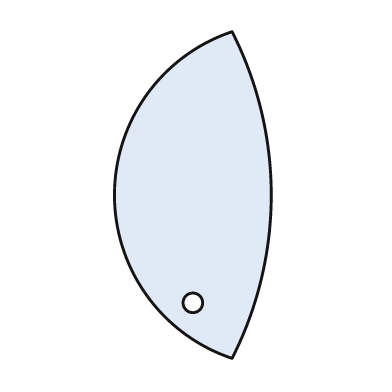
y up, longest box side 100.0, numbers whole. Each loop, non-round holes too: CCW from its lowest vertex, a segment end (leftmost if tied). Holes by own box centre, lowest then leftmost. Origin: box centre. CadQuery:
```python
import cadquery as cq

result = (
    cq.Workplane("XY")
    .moveTo(12.0, -50.0)
    .threePointArc((24.0, 0.0), (12.0, 50.0))
    .threePointArc((-24.0, 0.0), (12.0, -50.0))
    .close()
    .moveTo(0.0, -33.0)
    .circle(3.0)
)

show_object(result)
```